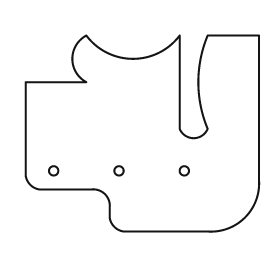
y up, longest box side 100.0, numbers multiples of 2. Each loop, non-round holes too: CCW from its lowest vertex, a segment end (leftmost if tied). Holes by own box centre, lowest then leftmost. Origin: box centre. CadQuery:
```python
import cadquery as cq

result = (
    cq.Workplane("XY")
    .moveTo(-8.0, -42.0)
    .lineTo(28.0, -42.0)
    .threePointArc((44.0, -36.0), (50.0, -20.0))
    .lineTo(50.0, 42.0)
    .lineTo(28.0, 42.0)
    .threePointArc((24.0, 22.0), (28.0, 2.0))
    .threePointArc((22.0, -2.0), (16.0, 2.0))
    .lineTo(16.0, 42.0)
    .threePointArc((-4.0, 32.0), (-24.0, 42.0))
    .threePointArc((-30.0, 32.0), (-24.0, 22.0))
    .lineTo(-50.0, 22.0)
    .lineTo(-50.0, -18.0)
    .threePointArc((-48.0, -22.0), (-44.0, -24.0))
    .lineTo(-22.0, -24.0)
    .threePointArc((-16.0, -26.0), (-14.0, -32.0))
    .lineTo(-14.0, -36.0)
    .threePointArc((-12.0, -40.0), (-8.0, -42.0))
    .close()
    .moveTo(-38.0, -16.0)
    .circle(2.0)
    .moveTo(-10.0, -16.0)
    .circle(2.0)
    .moveTo(18.0, -16.0)
    .circle(2.0)
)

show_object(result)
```